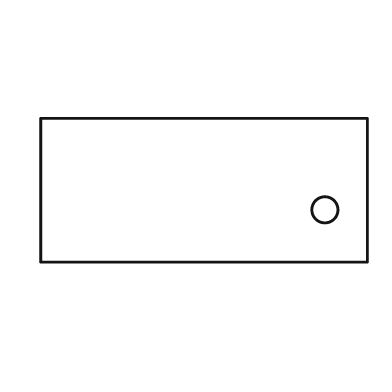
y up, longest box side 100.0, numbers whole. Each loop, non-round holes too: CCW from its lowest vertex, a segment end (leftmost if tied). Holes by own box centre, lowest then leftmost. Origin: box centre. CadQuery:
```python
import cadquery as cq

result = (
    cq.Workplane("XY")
    .moveTo(-50.0, -22.0)
    .lineTo(50.0, -22.0)
    .lineTo(50.0, 22.0)
    .lineTo(-50.0, 22.0)
    .close()
    .moveTo(37.0, -6.0)
    .circle(4.0)
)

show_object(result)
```